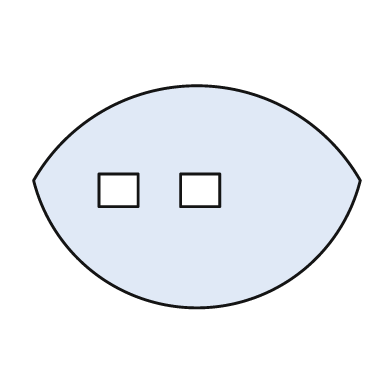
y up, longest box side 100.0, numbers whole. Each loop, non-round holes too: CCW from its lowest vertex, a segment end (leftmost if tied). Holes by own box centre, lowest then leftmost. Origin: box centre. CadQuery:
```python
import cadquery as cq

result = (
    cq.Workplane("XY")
    .moveTo(-50.0, 5.0)
    .threePointArc((0.0, -34.0), (50.0, 5.0))
    .threePointArc((0.0, 34.0), (-50.0, 5.0))
    .close()
    .moveTo(-30.0, -3.0)
    .lineTo(-18.0, -3.0)
    .lineTo(-18.0, 7.0)
    .lineTo(-30.0, 7.0)
    .close()
    .moveTo(-5.0, -3.0)
    .lineTo(7.0, -3.0)
    .lineTo(7.0, 7.0)
    .lineTo(-5.0, 7.0)
    .close()
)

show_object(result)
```